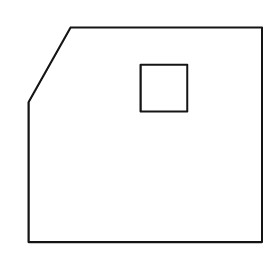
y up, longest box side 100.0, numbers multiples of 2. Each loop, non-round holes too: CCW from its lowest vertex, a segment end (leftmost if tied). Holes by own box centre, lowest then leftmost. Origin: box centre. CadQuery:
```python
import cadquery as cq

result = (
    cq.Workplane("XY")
    .moveTo(-50.0, -46.0)
    .lineTo(50.0, -46.0)
    .lineTo(50.0, 46.0)
    .lineTo(-32.0, 46.0)
    .lineTo(-50.0, 14.0)
    .close()
    .moveTo(-2.0, 10.0)
    .lineTo(18.0, 10.0)
    .lineTo(18.0, 30.0)
    .lineTo(-2.0, 30.0)
    .close()
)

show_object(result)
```